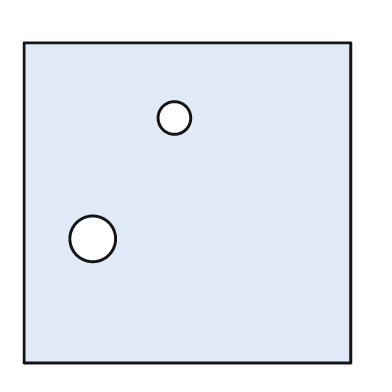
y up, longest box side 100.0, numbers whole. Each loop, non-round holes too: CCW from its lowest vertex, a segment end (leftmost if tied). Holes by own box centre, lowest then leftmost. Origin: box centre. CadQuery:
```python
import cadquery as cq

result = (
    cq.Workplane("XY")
    .moveTo(-50.0, -49.0)
    .lineTo(50.0, -49.0)
    .lineTo(50.0, 49.0)
    .lineTo(-50.0, 49.0)
    .close()
    .moveTo(-29.0, -11.0)
    .circle(7.0)
    .moveTo(-4.0, 26.0)
    .circle(5.0)
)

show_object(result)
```